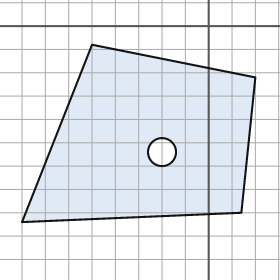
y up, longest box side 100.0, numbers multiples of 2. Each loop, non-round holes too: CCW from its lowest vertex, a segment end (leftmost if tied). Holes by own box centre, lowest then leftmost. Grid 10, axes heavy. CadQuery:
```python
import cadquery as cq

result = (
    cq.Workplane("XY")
    .moveTo(-80.0, -84.0)
    .lineTo(14.0, -80.0)
    .lineTo(20.0, -22.0)
    .lineTo(-50.0, -8.0)
    .close()
    .moveTo(-20.0, -54.0)
    .circle(6.0)
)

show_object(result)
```